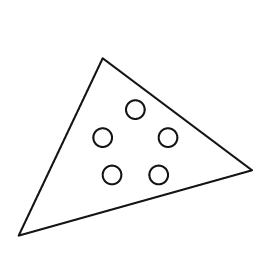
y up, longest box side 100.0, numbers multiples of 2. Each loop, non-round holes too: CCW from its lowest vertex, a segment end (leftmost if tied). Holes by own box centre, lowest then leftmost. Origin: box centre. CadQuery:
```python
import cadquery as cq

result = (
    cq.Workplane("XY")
    .moveTo(-50.0, -38.0)
    .lineTo(50.0, -10.0)
    .lineTo(-14.0, 38.0)
    .close()
    .moveTo(-10.0, -12.0)
    .circle(4.0)
    .moveTo(10.0, -12.0)
    .circle(4.0)
    .moveTo(-14.0, 4.0)
    .circle(4.0)
    .moveTo(14.0, 4.0)
    .circle(4.0)
    .moveTo(0.0, 16.0)
    .circle(4.0)
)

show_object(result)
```